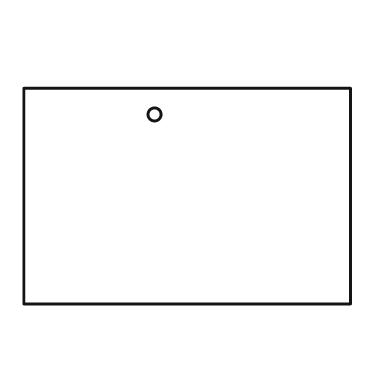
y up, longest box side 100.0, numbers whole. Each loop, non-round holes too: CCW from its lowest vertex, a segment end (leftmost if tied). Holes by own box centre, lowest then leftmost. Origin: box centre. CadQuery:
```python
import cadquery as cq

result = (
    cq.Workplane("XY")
    .moveTo(-50.0, -33.0)
    .lineTo(50.0, -33.0)
    .lineTo(50.0, 33.0)
    .lineTo(-50.0, 33.0)
    .close()
    .moveTo(-10.0, 25.0)
    .circle(2.0)
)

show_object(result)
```